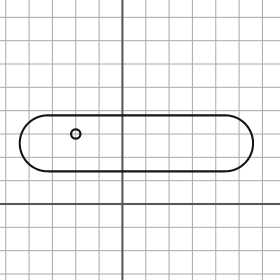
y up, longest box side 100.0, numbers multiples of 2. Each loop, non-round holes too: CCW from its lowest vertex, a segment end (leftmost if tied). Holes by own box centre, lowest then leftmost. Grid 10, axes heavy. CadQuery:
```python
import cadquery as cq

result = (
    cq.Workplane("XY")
    .moveTo(-32.0, 14.0)
    .lineTo(44.0, 14.0)
    .threePointArc((56.0, 26.0), (44.0, 38.0))
    .lineTo(-32.0, 38.0)
    .threePointArc((-44.0, 26.0), (-32.0, 14.0))
    .close()
    .moveTo(-20.0, 30.0)
    .circle(2.0)
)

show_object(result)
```